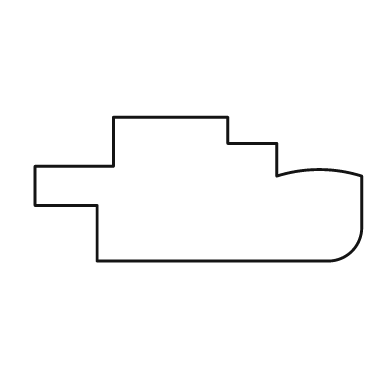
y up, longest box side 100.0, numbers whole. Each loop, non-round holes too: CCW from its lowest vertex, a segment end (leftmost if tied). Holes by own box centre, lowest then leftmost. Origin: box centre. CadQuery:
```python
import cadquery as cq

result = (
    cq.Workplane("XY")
    .moveTo(-31.0, -22.0)
    .lineTo(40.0, -22.0)
    .threePointArc((47.0, -19.0), (50.0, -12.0))
    .lineTo(50.0, 4.0)
    .threePointArc((37.0, 6.0), (24.0, 4.0))
    .lineTo(24.0, 14.0)
    .lineTo(9.0, 14.0)
    .lineTo(9.0, 22.0)
    .lineTo(-26.0, 22.0)
    .lineTo(-26.0, 7.0)
    .lineTo(-50.0, 7.0)
    .lineTo(-50.0, -5.0)
    .lineTo(-31.0, -5.0)
    .close()
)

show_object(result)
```